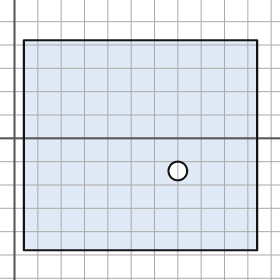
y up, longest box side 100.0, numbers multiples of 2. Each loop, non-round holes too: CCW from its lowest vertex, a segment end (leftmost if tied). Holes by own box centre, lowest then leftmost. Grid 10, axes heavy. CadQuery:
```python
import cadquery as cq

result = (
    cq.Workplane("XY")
    .moveTo(4.0, -48.0)
    .lineTo(104.0, -48.0)
    .lineTo(104.0, 42.0)
    .lineTo(4.0, 42.0)
    .close()
    .moveTo(70.0, -14.0)
    .circle(4.0)
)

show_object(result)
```